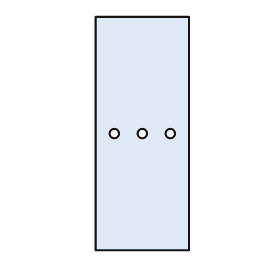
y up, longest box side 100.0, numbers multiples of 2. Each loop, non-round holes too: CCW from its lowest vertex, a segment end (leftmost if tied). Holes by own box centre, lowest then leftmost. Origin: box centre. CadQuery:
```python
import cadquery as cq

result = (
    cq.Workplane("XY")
    .moveTo(-20.0, -50.0)
    .lineTo(20.0, -50.0)
    .lineTo(20.0, 50.0)
    .lineTo(-20.0, 50.0)
    .close()
    .moveTo(-12.0, 0.0)
    .circle(2.0)
    .moveTo(0.0, 0.0)
    .circle(2.0)
    .moveTo(12.0, 0.0)
    .circle(2.0)
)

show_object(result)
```